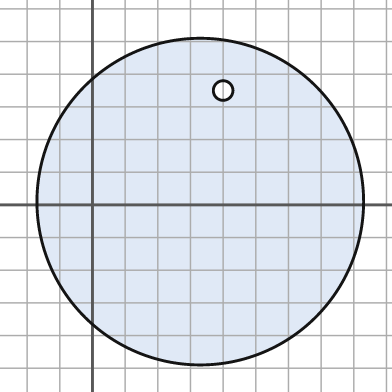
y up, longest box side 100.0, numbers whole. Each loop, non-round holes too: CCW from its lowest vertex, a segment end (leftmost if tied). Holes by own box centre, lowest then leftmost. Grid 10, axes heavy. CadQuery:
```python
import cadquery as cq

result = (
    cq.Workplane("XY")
    .moveTo(33.0, 1.0)
    .circle(50.0)
    .moveTo(40.0, 35.0)
    .circle(3.0)
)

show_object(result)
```